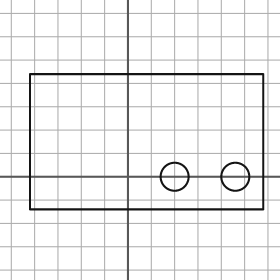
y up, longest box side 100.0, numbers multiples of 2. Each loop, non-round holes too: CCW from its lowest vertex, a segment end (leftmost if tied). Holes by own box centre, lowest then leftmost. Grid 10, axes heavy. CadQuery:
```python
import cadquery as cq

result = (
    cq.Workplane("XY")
    .moveTo(-42.0, -14.0)
    .lineTo(58.0, -14.0)
    .lineTo(58.0, 44.0)
    .lineTo(-42.0, 44.0)
    .close()
    .moveTo(20.0, 0.0)
    .circle(6.0)
    .moveTo(46.0, 0.0)
    .circle(6.0)
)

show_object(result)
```